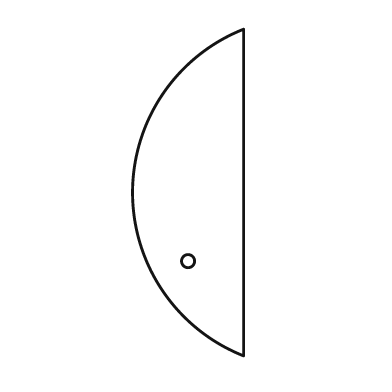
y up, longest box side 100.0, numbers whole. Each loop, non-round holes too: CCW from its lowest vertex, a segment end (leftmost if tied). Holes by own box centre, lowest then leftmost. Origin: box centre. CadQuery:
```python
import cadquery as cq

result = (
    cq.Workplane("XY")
    .moveTo(17.0, -50.0)
    .lineTo(17.0, 50.0)
    .threePointArc((-17.0, 0.0), (17.0, -50.0))
    .close()
    .moveTo(0.0, -21.0)
    .circle(2.0)
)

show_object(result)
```